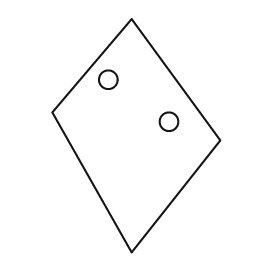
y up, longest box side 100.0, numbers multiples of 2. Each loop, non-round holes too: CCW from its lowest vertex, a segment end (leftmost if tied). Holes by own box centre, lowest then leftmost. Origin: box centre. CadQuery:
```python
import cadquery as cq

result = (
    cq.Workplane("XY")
    .moveTo(-2.0, -50.0)
    .lineTo(36.0, -2.0)
    .lineTo(-2.0, 50.0)
    .lineTo(-36.0, 10.0)
    .close()
    .moveTo(14.0, 6.0)
    .circle(4.0)
    .moveTo(-12.0, 24.0)
    .circle(4.0)
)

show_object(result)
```